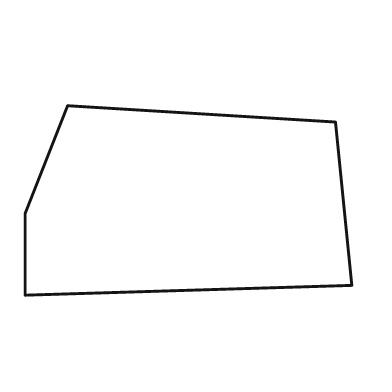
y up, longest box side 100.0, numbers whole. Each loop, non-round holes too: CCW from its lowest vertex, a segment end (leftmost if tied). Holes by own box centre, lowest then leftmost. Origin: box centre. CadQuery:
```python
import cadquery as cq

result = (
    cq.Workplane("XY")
    .moveTo(-50.0, -29.0)
    .lineTo(50.0, -26.0)
    .lineTo(45.0, 24.0)
    .lineTo(-37.0, 29.0)
    .lineTo(-50.0, -4.0)
    .close()
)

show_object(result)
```